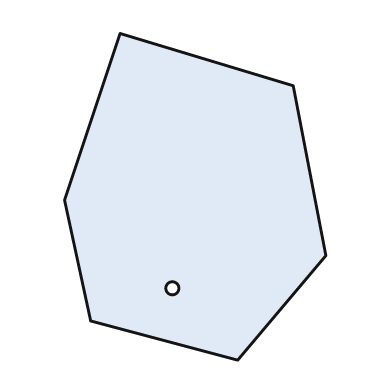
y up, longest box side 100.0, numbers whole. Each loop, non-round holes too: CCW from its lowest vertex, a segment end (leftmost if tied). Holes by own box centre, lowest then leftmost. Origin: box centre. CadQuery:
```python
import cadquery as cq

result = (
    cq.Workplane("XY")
    .moveTo(13.0, -50.0)
    .lineTo(40.0, -18.0)
    .lineTo(30.0, 34.0)
    .lineTo(-23.0, 50.0)
    .lineTo(-40.0, -1.0)
    .lineTo(-32.0, -38.0)
    .close()
    .moveTo(-7.0, -28.0)
    .circle(2.0)
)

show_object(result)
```